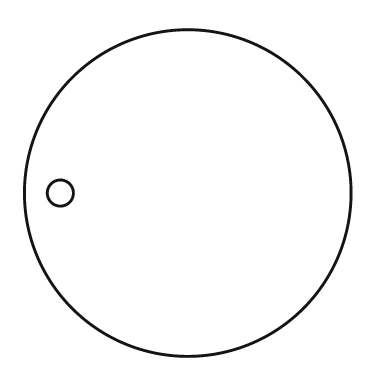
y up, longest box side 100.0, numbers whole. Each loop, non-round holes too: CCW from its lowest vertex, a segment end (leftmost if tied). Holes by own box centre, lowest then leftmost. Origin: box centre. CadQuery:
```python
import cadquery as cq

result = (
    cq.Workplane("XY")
    .moveTo(0.0, 0.0)
    .circle(50.0)
    .moveTo(-39.0, 0.0)
    .circle(4.0)
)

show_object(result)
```